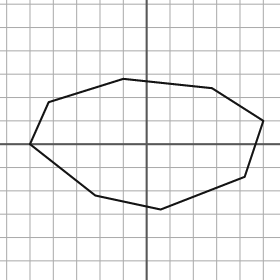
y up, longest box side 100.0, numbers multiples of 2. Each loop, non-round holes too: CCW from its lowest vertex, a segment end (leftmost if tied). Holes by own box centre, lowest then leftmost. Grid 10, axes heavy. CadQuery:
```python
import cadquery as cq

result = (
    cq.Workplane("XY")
    .moveTo(6.0, -28.0)
    .lineTo(42.0, -14.0)
    .lineTo(50.0, 10.0)
    .lineTo(28.0, 24.0)
    .lineTo(-10.0, 28.0)
    .lineTo(-42.0, 18.0)
    .lineTo(-50.0, 0.0)
    .lineTo(-22.0, -22.0)
    .close()
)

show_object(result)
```